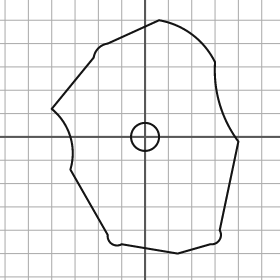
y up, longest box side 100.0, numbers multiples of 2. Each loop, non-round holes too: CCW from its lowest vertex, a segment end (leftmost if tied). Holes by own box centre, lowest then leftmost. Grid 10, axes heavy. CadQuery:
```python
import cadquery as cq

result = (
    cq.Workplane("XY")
    .moveTo(14.0, -50.0)
    .lineTo(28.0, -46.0)
    .threePointArc((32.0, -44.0), (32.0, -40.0))
    .lineTo(40.0, -2.0)
    .threePointArc((32.0, 14.0), (30.0, 32.0))
    .threePointArc((20.0, 44.0), (6.0, 50.0))
    .lineTo(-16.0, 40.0)
    .threePointArc((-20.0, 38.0), (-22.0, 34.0))
    .lineTo(-40.0, 12.0)
    .threePointArc((-32.0, 0.0), (-32.0, -14.0))
    .lineTo(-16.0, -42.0)
    .threePointArc((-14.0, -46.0), (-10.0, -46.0))
    .close()
    .moveTo(0.0, 0.0)
    .circle(6.0)
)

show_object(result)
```